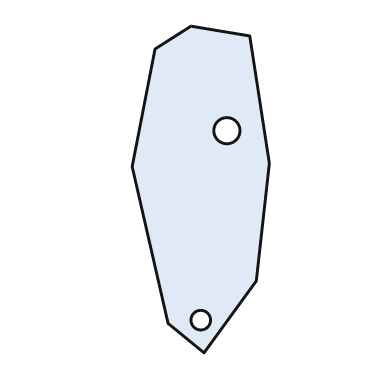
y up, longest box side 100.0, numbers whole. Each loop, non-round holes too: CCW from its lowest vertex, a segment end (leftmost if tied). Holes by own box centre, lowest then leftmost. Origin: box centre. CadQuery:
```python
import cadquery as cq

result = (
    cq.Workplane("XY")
    .moveTo(1.0, -50.0)
    .lineTo(17.0, -28.0)
    .lineTo(21.0, 8.0)
    .lineTo(15.0, 47.0)
    .lineTo(-3.0, 50.0)
    .lineTo(-14.0, 43.0)
    .lineTo(-21.0, 7.0)
    .lineTo(-10.0, -41.0)
    .close()
    .moveTo(0.0, -40.0)
    .circle(3.0)
    .moveTo(8.0, 18.0)
    .circle(4.0)
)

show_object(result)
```